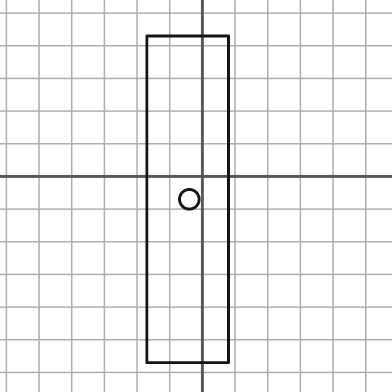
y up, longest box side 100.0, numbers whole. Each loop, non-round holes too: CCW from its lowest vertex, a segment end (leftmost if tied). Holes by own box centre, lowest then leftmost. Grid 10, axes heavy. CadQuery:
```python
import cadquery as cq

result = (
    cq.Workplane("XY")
    .moveTo(-17.0, -57.0)
    .lineTo(8.0, -57.0)
    .lineTo(8.0, 43.0)
    .lineTo(-17.0, 43.0)
    .close()
    .moveTo(-4.0, -7.0)
    .circle(3.0)
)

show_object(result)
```